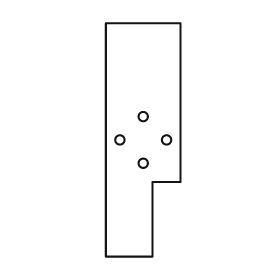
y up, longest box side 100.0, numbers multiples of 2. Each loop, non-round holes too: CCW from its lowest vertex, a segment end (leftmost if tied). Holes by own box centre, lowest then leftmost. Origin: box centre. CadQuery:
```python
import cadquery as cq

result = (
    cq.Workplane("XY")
    .moveTo(-16.0, -50.0)
    .lineTo(4.0, -50.0)
    .lineTo(4.0, -18.0)
    .lineTo(16.0, -18.0)
    .lineTo(16.0, 50.0)
    .lineTo(-16.0, 50.0)
    .close()
    .moveTo(0.0, -10.0)
    .circle(2.0)
    .moveTo(-10.0, 0.0)
    .circle(2.0)
    .moveTo(10.0, 0.0)
    .circle(2.0)
    .moveTo(0.0, 10.0)
    .circle(2.0)
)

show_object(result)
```